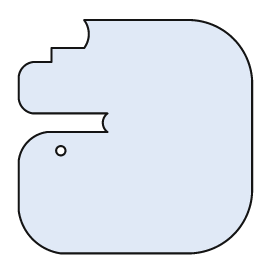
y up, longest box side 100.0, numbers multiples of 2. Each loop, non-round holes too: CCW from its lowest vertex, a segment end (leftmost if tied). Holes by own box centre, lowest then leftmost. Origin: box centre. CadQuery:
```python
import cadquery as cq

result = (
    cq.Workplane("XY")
    .moveTo(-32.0, -50.0)
    .lineTo(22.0, -50.0)
    .threePointArc((42.0, -42.0), (50.0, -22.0))
    .lineTo(50.0, 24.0)
    .threePointArc((42.0, 42.0), (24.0, 50.0))
    .lineTo(-22.0, 50.0)
    .threePointArc((-20.0, 44.0), (-22.0, 38.0))
    .lineTo(-36.0, 38.0)
    .lineTo(-36.0, 32.0)
    .lineTo(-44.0, 32.0)
    .threePointArc((-48.0, 30.0), (-50.0, 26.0))
    .lineTo(-50.0, 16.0)
    .threePointArc((-48.0, 12.0), (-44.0, 10.0))
    .lineTo(-12.0, 10.0)
    .threePointArc((-14.0, 6.0), (-12.0, 2.0))
    .lineTo(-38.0, 2.0)
    .threePointArc((-46.0, -2.0), (-50.0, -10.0))
    .lineTo(-50.0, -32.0)
    .threePointArc((-44.0, -44.0), (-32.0, -50.0))
    .close()
    .moveTo(-32.0, -6.0)
    .circle(2.0)
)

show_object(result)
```